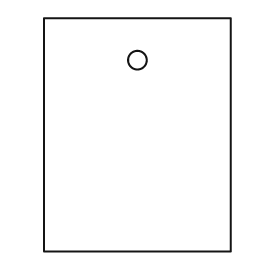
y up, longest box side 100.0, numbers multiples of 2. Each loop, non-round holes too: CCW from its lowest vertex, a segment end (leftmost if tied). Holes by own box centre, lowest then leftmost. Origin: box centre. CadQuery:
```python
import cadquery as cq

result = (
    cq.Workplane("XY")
    .moveTo(-40.0, -50.0)
    .lineTo(40.0, -50.0)
    .lineTo(40.0, 50.0)
    .lineTo(-40.0, 50.0)
    .close()
    .moveTo(0.0, 32.0)
    .circle(4.0)
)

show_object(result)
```